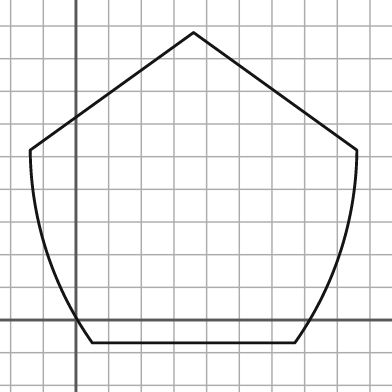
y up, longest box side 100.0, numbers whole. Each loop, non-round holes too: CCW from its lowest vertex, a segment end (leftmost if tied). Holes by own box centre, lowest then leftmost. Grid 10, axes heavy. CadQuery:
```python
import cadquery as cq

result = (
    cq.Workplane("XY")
    .moveTo(5.0, -7.0)
    .lineTo(67.0, -7.0)
    .threePointArc((81.0, 21.0), (86.0, 52.0))
    .lineTo(36.0, 88.0)
    .lineTo(-14.0, 52.0)
    .threePointArc((-9.0, 21.0), (5.0, -7.0))
    .close()
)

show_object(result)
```